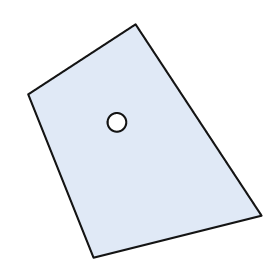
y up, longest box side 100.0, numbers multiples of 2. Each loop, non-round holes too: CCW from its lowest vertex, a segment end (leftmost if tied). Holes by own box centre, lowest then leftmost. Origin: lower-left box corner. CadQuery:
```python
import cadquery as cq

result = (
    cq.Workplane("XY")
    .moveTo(28.0, 0.0)
    .lineTo(100.0, 18.0)
    .lineTo(46.0, 100.0)
    .lineTo(0.0, 70.0)
    .close()
    .moveTo(38.0, 58.0)
    .circle(4.0)
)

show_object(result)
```